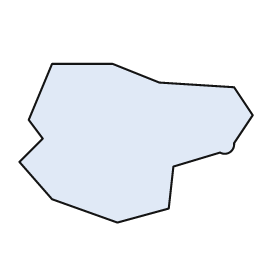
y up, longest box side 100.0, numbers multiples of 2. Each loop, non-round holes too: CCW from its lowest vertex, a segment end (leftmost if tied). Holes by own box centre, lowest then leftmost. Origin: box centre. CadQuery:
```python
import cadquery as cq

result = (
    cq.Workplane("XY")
    .moveTo(-8.0, -34.0)
    .lineTo(14.0, -28.0)
    .lineTo(16.0, -10.0)
    .lineTo(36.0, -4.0)
    .threePointArc((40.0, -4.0), (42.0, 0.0))
    .lineTo(50.0, 12.0)
    .lineTo(42.0, 24.0)
    .lineTo(10.0, 26.0)
    .lineTo(-10.0, 34.0)
    .lineTo(-36.0, 34.0)
    .lineTo(-46.0, 10.0)
    .lineTo(-40.0, 2.0)
    .lineTo(-50.0, -8.0)
    .lineTo(-36.0, -24.0)
    .close()
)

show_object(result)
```